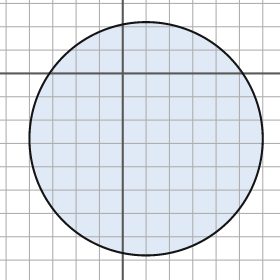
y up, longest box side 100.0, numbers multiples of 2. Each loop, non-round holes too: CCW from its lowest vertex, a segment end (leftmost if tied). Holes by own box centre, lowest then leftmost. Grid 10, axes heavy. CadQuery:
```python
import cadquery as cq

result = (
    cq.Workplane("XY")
    .moveTo(10.0, -28.0)
    .circle(50.0)
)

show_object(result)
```